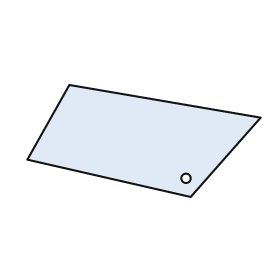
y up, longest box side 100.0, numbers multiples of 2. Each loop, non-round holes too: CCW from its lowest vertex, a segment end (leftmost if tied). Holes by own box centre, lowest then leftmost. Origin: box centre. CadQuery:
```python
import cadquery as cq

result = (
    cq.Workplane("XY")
    .moveTo(20.0, -24.0)
    .lineTo(50.0, 10.0)
    .lineTo(-32.0, 24.0)
    .lineTo(-50.0, -8.0)
    .close()
    .moveTo(18.0, -16.0)
    .circle(2.0)
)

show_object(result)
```